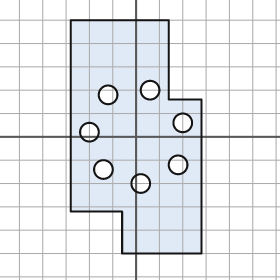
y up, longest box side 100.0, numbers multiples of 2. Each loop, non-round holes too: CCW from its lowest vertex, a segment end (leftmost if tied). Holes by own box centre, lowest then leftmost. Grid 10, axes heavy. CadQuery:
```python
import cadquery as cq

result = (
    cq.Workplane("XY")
    .moveTo(-6.0, -50.0)
    .lineTo(28.0, -50.0)
    .lineTo(28.0, 16.0)
    .lineTo(14.0, 16.0)
    .lineTo(14.0, 50.0)
    .lineTo(-28.0, 50.0)
    .lineTo(-28.0, -32.0)
    .lineTo(-6.0, -32.0)
    .close()
    .moveTo(2.0, -20.0)
    .circle(4.0)
    .moveTo(-14.0, -14.0)
    .circle(4.0)
    .moveTo(18.0, -12.0)
    .circle(4.0)
    .moveTo(-20.0, 2.0)
    .circle(4.0)
    .moveTo(20.0, 6.0)
    .circle(4.0)
    .moveTo(-12.0, 18.0)
    .circle(4.0)
    .moveTo(6.0, 20.0)
    .circle(4.0)
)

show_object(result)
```